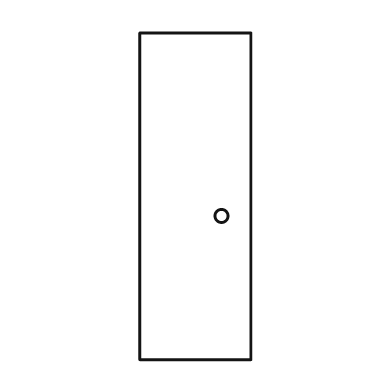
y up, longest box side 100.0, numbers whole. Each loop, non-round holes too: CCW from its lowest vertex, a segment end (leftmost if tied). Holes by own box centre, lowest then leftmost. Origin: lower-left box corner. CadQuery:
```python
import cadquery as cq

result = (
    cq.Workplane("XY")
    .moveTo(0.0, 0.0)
    .lineTo(34.0, 0.0)
    .lineTo(34.0, 100.0)
    .lineTo(0.0, 100.0)
    .close()
    .moveTo(25.0, 44.0)
    .circle(2.0)
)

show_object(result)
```